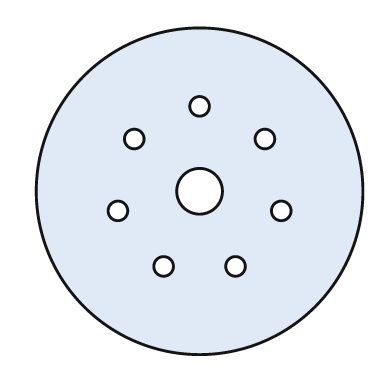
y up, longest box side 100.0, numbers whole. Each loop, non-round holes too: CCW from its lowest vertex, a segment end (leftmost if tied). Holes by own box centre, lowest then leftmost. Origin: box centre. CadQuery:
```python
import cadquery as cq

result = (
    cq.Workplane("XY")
    .moveTo(0.0, 0.0)
    .circle(50.0)
    .moveTo(-11.0, -23.0)
    .circle(3.0)
    .moveTo(11.0, -23.0)
    .circle(3.0)
    .moveTo(-25.0, -6.0)
    .circle(3.0)
    .moveTo(25.0, -6.0)
    .circle(3.0)
    .moveTo(0.0, 0.0)
    .circle(7.0)
    .moveTo(-20.0, 16.0)
    .circle(3.0)
    .moveTo(20.0, 16.0)
    .circle(3.0)
    .moveTo(0.0, 26.0)
    .circle(3.0)
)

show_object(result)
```